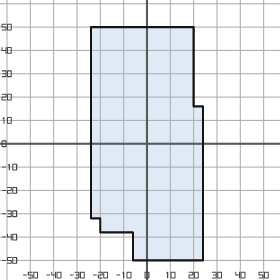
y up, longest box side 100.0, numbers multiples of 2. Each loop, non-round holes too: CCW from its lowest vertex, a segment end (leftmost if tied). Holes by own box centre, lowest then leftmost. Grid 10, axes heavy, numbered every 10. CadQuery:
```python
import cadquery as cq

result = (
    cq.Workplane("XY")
    .moveTo(-6.0, -50.0)
    .lineTo(24.0, -50.0)
    .lineTo(24.0, 16.0)
    .lineTo(20.0, 16.0)
    .lineTo(20.0, 50.0)
    .lineTo(-24.0, 50.0)
    .lineTo(-24.0, -32.0)
    .lineTo(-20.0, -32.0)
    .lineTo(-20.0, -38.0)
    .lineTo(-6.0, -38.0)
    .close()
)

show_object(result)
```